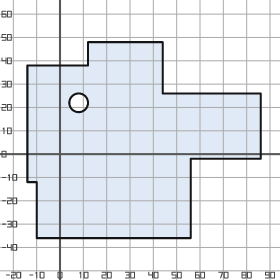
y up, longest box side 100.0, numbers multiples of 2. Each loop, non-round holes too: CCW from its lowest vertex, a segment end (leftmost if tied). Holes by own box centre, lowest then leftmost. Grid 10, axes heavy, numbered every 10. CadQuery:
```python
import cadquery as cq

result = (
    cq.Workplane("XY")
    .moveTo(-10.0, -36.0)
    .lineTo(56.0, -36.0)
    .lineTo(56.0, -2.0)
    .lineTo(86.0, -2.0)
    .lineTo(86.0, 26.0)
    .lineTo(44.0, 26.0)
    .lineTo(44.0, 48.0)
    .lineTo(12.0, 48.0)
    .lineTo(12.0, 38.0)
    .lineTo(-14.0, 38.0)
    .lineTo(-14.0, -12.0)
    .lineTo(-10.0, -12.0)
    .close()
    .moveTo(8.0, 22.0)
    .circle(4.0)
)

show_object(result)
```